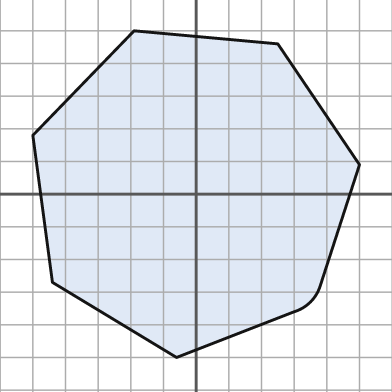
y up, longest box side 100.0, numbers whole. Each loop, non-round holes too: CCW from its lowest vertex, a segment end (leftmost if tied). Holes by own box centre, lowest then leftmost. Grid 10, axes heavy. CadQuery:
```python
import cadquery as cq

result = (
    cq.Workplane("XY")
    .moveTo(-6.0, -50.0)
    .lineTo(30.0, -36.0)
    .threePointArc((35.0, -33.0), (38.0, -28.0))
    .lineTo(50.0, 9.0)
    .lineTo(25.0, 46.0)
    .lineTo(-19.0, 50.0)
    .lineTo(-50.0, 18.0)
    .lineTo(-44.0, -27.0)
    .close()
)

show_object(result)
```